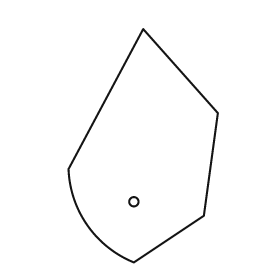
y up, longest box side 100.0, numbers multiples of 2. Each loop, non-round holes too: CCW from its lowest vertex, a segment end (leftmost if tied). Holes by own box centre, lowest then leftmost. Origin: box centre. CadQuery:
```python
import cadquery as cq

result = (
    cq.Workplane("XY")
    .moveTo(-4.0, -50.0)
    .lineTo(26.0, -30.0)
    .lineTo(32.0, 14.0)
    .lineTo(0.0, 50.0)
    .lineTo(-32.0, -10.0)
    .threePointArc((-24.0, -34.0), (-4.0, -50.0))
    .close()
    .moveTo(-4.0, -24.0)
    .circle(2.0)
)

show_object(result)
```